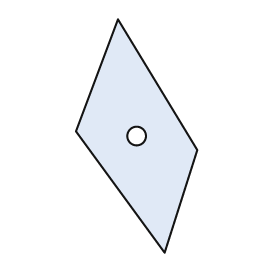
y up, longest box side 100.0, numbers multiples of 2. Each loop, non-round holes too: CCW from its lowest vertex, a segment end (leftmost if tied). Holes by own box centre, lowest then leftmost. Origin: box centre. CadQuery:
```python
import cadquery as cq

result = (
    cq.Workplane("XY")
    .moveTo(12.0, -50.0)
    .lineTo(26.0, -6.0)
    .lineTo(-8.0, 50.0)
    .lineTo(-26.0, 2.0)
    .close()
    .moveTo(0.0, 0.0)
    .circle(4.0)
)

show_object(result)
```